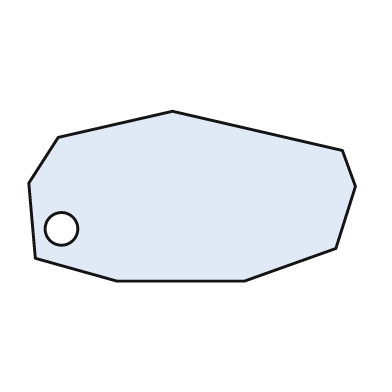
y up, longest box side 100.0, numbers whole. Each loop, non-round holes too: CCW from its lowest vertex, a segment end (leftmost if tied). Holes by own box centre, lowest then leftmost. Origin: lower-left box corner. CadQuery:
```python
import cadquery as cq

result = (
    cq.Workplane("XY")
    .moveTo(27.0, 0.0)
    .lineTo(66.0, 0.0)
    .lineTo(94.0, 10.0)
    .lineTo(100.0, 29.0)
    .lineTo(96.0, 40.0)
    .lineTo(44.0, 52.0)
    .lineTo(9.0, 44.0)
    .lineTo(0.0, 30.0)
    .lineTo(2.0, 7.0)
    .close()
    .moveTo(10.0, 16.0)
    .circle(5.0)
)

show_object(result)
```